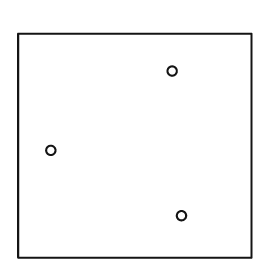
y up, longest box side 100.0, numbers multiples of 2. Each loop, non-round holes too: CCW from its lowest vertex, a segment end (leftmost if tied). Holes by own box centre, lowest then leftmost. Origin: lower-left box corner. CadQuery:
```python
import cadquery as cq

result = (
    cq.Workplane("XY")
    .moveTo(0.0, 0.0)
    .lineTo(100.0, 0.0)
    .lineTo(100.0, 96.0)
    .lineTo(0.0, 96.0)
    .close()
    .moveTo(70.0, 18.0)
    .circle(2.0)
    .moveTo(14.0, 46.0)
    .circle(2.0)
    .moveTo(66.0, 80.0)
    .circle(2.0)
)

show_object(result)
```